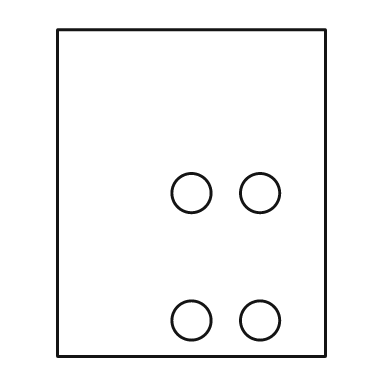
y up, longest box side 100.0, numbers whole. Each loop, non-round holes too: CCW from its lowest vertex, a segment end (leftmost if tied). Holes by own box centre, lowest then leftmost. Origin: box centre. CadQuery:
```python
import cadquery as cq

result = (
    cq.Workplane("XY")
    .moveTo(-41.0, -50.0)
    .lineTo(41.0, -50.0)
    .lineTo(41.0, 50.0)
    .lineTo(-41.0, 50.0)
    .close()
    .moveTo(0.0, -39.0)
    .circle(6.0)
    .moveTo(21.0, -39.0)
    .circle(6.0)
    .moveTo(0.0, 0.0)
    .circle(6.0)
    .moveTo(21.0, 0.0)
    .circle(6.0)
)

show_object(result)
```